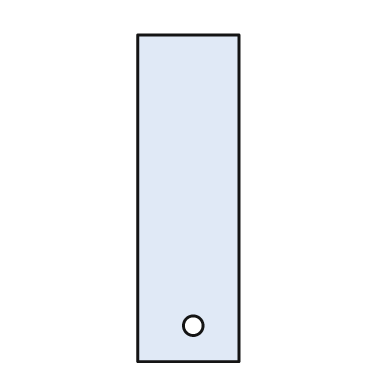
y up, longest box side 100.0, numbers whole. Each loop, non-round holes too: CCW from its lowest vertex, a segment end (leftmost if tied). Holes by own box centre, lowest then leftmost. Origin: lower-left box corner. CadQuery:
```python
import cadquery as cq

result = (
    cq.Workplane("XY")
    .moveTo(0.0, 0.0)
    .lineTo(31.0, 0.0)
    .lineTo(31.0, 100.0)
    .lineTo(0.0, 100.0)
    .close()
    .moveTo(17.0, 11.0)
    .circle(3.0)
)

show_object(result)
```